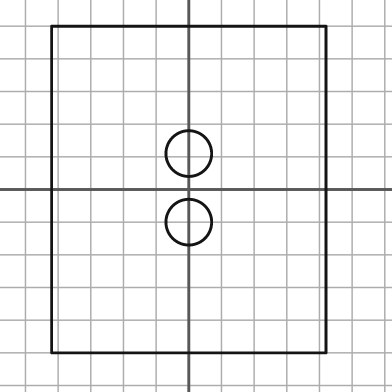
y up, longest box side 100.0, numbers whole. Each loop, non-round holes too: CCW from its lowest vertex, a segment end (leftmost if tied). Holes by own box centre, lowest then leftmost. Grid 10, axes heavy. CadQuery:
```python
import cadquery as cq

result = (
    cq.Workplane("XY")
    .moveTo(-42.0, -50.0)
    .lineTo(42.0, -50.0)
    .lineTo(42.0, 50.0)
    .lineTo(-42.0, 50.0)
    .close()
    .moveTo(0.0, -10.0)
    .circle(7.0)
    .moveTo(0.0, 11.0)
    .circle(7.0)
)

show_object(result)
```